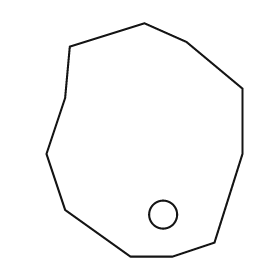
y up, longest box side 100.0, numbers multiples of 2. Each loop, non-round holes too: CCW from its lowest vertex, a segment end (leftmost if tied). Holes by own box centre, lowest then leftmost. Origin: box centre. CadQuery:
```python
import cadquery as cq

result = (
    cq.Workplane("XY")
    .moveTo(-6.0, -50.0)
    .lineTo(12.0, -50.0)
    .lineTo(30.0, -44.0)
    .lineTo(42.0, -6.0)
    .lineTo(42.0, 22.0)
    .lineTo(18.0, 42.0)
    .lineTo(0.0, 50.0)
    .lineTo(-32.0, 40.0)
    .lineTo(-34.0, 18.0)
    .lineTo(-42.0, -6.0)
    .lineTo(-34.0, -30.0)
    .close()
    .moveTo(8.0, -32.0)
    .circle(6.0)
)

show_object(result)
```